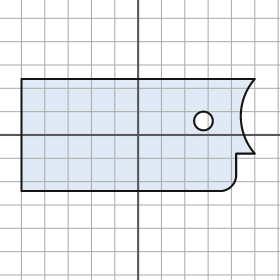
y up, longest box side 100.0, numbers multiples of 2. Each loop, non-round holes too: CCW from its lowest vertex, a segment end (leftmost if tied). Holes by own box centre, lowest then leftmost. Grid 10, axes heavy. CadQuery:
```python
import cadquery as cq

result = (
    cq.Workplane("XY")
    .moveTo(-50.0, -24.0)
    .lineTo(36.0, -24.0)
    .threePointArc((40.0, -22.0), (42.0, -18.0))
    .lineTo(42.0, -8.0)
    .lineTo(50.0, -8.0)
    .threePointArc((44.0, 8.0), (50.0, 24.0))
    .lineTo(-50.0, 24.0)
    .close()
    .moveTo(28.0, 6.0)
    .circle(4.0)
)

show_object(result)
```